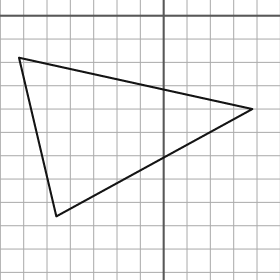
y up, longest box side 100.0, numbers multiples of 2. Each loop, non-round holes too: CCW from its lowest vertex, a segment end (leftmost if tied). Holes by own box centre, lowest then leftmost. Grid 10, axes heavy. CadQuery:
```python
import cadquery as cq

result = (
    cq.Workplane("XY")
    .moveTo(-46.0, -86.0)
    .lineTo(38.0, -40.0)
    .lineTo(-62.0, -18.0)
    .close()
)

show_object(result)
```